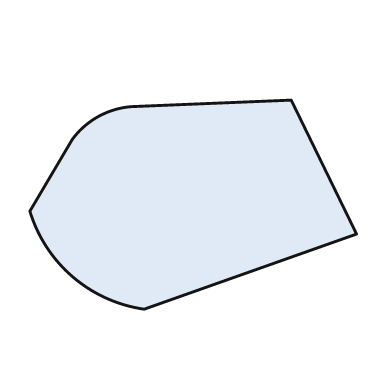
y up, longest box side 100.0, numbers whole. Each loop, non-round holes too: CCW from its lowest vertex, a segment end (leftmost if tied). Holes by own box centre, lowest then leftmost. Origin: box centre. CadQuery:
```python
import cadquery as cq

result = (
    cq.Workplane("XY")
    .moveTo(-15.0, -32.0)
    .lineTo(50.0, -9.0)
    .lineTo(30.0, 32.0)
    .lineTo(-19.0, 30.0)
    .threePointArc((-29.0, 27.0), (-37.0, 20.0))
    .lineTo(-50.0, -2.0)
    .threePointArc((-37.0, -22.0), (-15.0, -32.0))
    .close()
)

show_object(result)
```